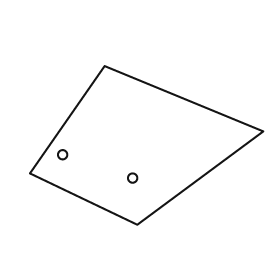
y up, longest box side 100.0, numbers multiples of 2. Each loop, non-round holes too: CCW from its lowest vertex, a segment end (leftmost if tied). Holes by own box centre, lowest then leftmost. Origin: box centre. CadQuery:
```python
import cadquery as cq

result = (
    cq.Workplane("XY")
    .moveTo(-4.0, -34.0)
    .lineTo(50.0, 6.0)
    .lineTo(-18.0, 34.0)
    .lineTo(-50.0, -12.0)
    .close()
    .moveTo(-6.0, -14.0)
    .circle(2.0)
    .moveTo(-36.0, -4.0)
    .circle(2.0)
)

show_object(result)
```